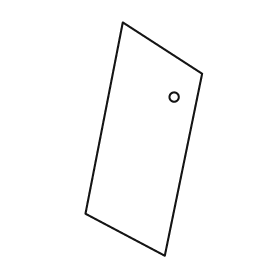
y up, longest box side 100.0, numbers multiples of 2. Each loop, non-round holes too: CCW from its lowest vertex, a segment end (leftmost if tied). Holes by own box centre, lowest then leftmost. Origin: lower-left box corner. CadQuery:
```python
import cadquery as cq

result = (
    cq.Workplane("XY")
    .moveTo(34.0, 0.0)
    .lineTo(50.0, 78.0)
    .lineTo(16.0, 100.0)
    .lineTo(0.0, 18.0)
    .close()
    .moveTo(38.0, 68.0)
    .circle(2.0)
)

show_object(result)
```